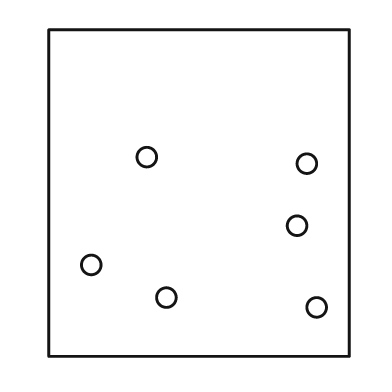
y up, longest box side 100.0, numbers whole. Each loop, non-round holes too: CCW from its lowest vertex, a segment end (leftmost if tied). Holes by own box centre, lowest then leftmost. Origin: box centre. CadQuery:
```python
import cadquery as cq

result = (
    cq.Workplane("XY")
    .moveTo(-46.0, -50.0)
    .lineTo(46.0, -50.0)
    .lineTo(46.0, 50.0)
    .lineTo(-46.0, 50.0)
    .close()
    .moveTo(36.0, -35.0)
    .circle(3.0)
    .moveTo(-10.0, -32.0)
    .circle(3.0)
    .moveTo(-33.0, -22.0)
    .circle(3.0)
    .moveTo(30.0, -10.0)
    .circle(3.0)
    .moveTo(33.0, 9.0)
    .circle(3.0)
    .moveTo(-16.0, 11.0)
    .circle(3.0)
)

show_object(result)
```